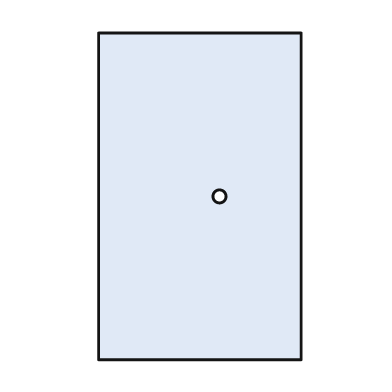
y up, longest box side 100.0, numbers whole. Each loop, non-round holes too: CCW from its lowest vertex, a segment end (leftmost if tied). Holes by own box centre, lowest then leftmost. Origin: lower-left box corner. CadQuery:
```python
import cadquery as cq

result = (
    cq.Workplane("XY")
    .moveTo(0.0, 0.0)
    .lineTo(62.0, 0.0)
    .lineTo(62.0, 100.0)
    .lineTo(0.0, 100.0)
    .close()
    .moveTo(37.0, 50.0)
    .circle(2.0)
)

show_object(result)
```